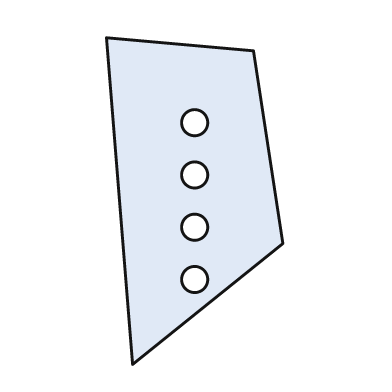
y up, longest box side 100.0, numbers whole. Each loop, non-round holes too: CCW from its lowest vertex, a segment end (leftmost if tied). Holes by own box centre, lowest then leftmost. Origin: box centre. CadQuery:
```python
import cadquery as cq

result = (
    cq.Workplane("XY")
    .moveTo(-19.0, -50.0)
    .lineTo(27.0, -13.0)
    .lineTo(18.0, 46.0)
    .lineTo(-27.0, 50.0)
    .close()
    .moveTo(0.0, -24.0)
    .circle(4.0)
    .moveTo(0.0, -8.0)
    .circle(4.0)
    .moveTo(0.0, 8.0)
    .circle(4.0)
    .moveTo(0.0, 24.0)
    .circle(4.0)
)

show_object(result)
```